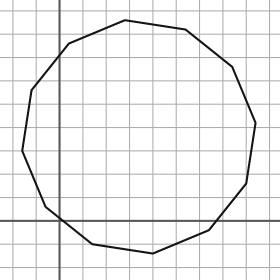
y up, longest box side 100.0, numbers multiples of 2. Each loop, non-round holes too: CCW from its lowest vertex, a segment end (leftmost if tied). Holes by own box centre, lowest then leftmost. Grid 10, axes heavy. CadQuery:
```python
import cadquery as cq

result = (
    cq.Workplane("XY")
    .moveTo(40.0, -14.0)
    .lineTo(64.0, -4.0)
    .lineTo(80.0, 16.0)
    .lineTo(84.0, 42.0)
    .lineTo(74.0, 66.0)
    .lineTo(54.0, 82.0)
    .lineTo(28.0, 86.0)
    .lineTo(4.0, 76.0)
    .lineTo(-12.0, 56.0)
    .lineTo(-16.0, 30.0)
    .lineTo(-6.0, 6.0)
    .lineTo(14.0, -10.0)
    .close()
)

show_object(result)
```